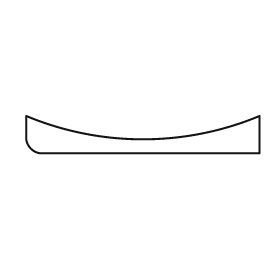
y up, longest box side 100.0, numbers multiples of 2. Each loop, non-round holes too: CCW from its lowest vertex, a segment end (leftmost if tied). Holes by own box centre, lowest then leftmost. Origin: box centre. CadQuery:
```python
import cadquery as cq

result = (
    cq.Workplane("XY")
    .moveTo(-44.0, -8.0)
    .lineTo(50.0, -8.0)
    .lineTo(50.0, 8.0)
    .threePointArc((0.0, -2.0), (-50.0, 8.0))
    .lineTo(-50.0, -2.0)
    .threePointArc((-48.0, -6.0), (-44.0, -8.0))
    .close()
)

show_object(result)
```